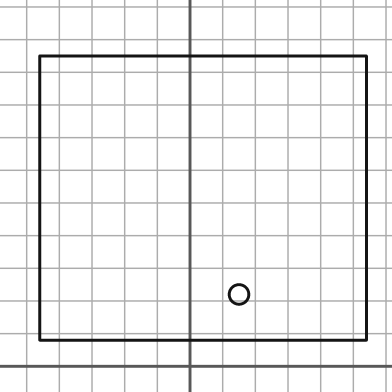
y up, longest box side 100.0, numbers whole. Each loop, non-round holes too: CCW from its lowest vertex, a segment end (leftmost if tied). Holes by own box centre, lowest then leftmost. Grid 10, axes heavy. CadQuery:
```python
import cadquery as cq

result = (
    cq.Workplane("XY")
    .moveTo(-46.0, 8.0)
    .lineTo(54.0, 8.0)
    .lineTo(54.0, 95.0)
    .lineTo(-46.0, 95.0)
    .close()
    .moveTo(15.0, 22.0)
    .circle(3.0)
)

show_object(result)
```